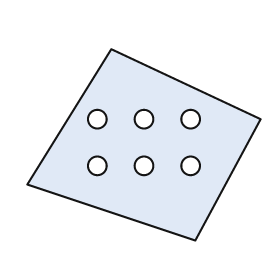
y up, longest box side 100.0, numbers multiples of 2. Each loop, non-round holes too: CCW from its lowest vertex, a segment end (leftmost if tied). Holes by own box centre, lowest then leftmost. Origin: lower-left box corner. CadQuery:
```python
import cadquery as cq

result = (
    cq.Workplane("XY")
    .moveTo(72.0, 0.0)
    .lineTo(100.0, 52.0)
    .lineTo(36.0, 82.0)
    .lineTo(0.0, 24.0)
    .close()
    .moveTo(30.0, 32.0)
    .circle(4.0)
    .moveTo(50.0, 32.0)
    .circle(4.0)
    .moveTo(70.0, 32.0)
    .circle(4.0)
    .moveTo(30.0, 52.0)
    .circle(4.0)
    .moveTo(50.0, 52.0)
    .circle(4.0)
    .moveTo(70.0, 52.0)
    .circle(4.0)
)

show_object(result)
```